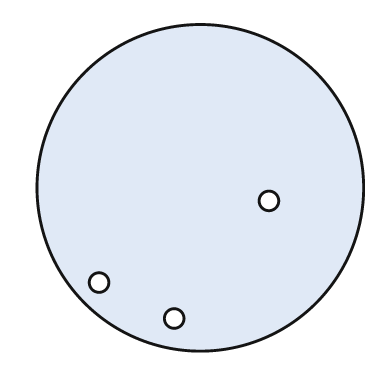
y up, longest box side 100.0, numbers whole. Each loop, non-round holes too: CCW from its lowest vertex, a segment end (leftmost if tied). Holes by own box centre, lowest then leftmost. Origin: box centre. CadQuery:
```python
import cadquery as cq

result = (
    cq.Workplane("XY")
    .moveTo(0.0, 0.0)
    .circle(50.0)
    .moveTo(-8.0, -40.0)
    .circle(3.0)
    .moveTo(-31.0, -29.0)
    .circle(3.0)
    .moveTo(21.0, -4.0)
    .circle(3.0)
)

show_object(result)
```